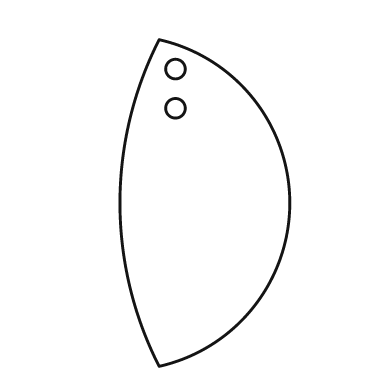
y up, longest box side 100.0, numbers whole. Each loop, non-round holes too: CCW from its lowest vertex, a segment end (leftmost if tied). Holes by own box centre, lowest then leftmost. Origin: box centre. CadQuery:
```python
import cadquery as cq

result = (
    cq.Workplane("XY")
    .moveTo(-14.0, -50.0)
    .threePointArc((26.0, 0.0), (-14.0, 50.0))
    .threePointArc((-26.0, 0.0), (-14.0, -50.0))
    .close()
    .moveTo(-9.0, 29.0)
    .circle(3.0)
    .moveTo(-9.0, 41.0)
    .circle(3.0)
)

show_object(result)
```